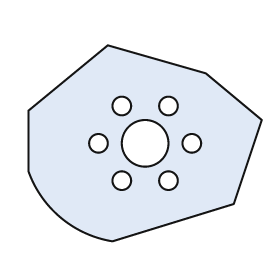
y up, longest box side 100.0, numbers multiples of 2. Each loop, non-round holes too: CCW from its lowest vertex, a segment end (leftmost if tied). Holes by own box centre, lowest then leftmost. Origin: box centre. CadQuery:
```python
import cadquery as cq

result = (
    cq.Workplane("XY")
    .moveTo(-14.0, -42.0)
    .lineTo(38.0, -26.0)
    .lineTo(50.0, 10.0)
    .lineTo(26.0, 30.0)
    .lineTo(-16.0, 42.0)
    .lineTo(-50.0, 14.0)
    .lineTo(-50.0, -12.0)
    .threePointArc((-36.0, -32.0), (-14.0, -42.0))
    .close()
    .moveTo(-10.0, -16.0)
    .circle(4.0)
    .moveTo(10.0, -16.0)
    .circle(4.0)
    .moveTo(-20.0, 0.0)
    .circle(4.0)
    .moveTo(0.0, 0.0)
    .circle(10.0)
    .moveTo(20.0, 0.0)
    .circle(4.0)
    .moveTo(-10.0, 16.0)
    .circle(4.0)
    .moveTo(10.0, 16.0)
    .circle(4.0)
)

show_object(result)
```